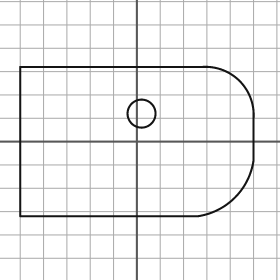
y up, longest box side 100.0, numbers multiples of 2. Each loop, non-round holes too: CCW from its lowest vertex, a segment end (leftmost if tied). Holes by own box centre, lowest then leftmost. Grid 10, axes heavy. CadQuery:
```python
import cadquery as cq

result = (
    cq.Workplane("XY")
    .moveTo(-50.0, -32.0)
    .lineTo(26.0, -32.0)
    .threePointArc((42.0, -24.0), (50.0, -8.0))
    .lineTo(50.0, 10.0)
    .threePointArc((44.0, 26.0), (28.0, 32.0))
    .lineTo(-50.0, 32.0)
    .close()
    .moveTo(2.0, 12.0)
    .circle(6.0)
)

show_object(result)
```